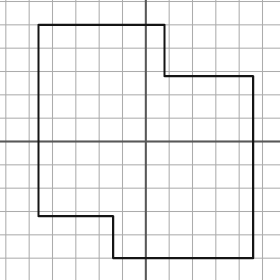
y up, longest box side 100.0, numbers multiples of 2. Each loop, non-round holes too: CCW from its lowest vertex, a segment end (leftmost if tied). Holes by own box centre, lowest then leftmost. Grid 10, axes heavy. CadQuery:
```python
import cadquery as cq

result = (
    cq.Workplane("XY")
    .moveTo(-14.0, -50.0)
    .lineTo(46.0, -50.0)
    .lineTo(46.0, 28.0)
    .lineTo(8.0, 28.0)
    .lineTo(8.0, 50.0)
    .lineTo(-46.0, 50.0)
    .lineTo(-46.0, -32.0)
    .lineTo(-14.0, -32.0)
    .close()
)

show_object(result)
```